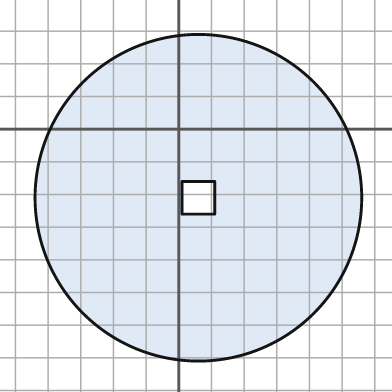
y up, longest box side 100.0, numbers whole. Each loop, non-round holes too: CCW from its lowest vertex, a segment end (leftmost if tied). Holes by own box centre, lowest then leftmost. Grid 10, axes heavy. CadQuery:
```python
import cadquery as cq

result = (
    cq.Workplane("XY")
    .moveTo(6.0, -21.0)
    .circle(50.0)
    .moveTo(1.0, -26.0)
    .lineTo(11.0, -26.0)
    .lineTo(11.0, -16.0)
    .lineTo(1.0, -16.0)
    .close()
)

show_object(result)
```